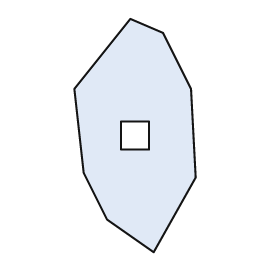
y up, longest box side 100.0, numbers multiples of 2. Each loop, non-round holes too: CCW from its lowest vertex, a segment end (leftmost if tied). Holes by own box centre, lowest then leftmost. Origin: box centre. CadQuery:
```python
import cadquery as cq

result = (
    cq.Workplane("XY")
    .moveTo(8.0, -50.0)
    .lineTo(26.0, -18.0)
    .lineTo(24.0, 20.0)
    .lineTo(12.0, 44.0)
    .lineTo(-2.0, 50.0)
    .lineTo(-26.0, 20.0)
    .lineTo(-22.0, -16.0)
    .lineTo(-12.0, -36.0)
    .close()
    .moveTo(-6.0, -6.0)
    .lineTo(6.0, -6.0)
    .lineTo(6.0, 6.0)
    .lineTo(-6.0, 6.0)
    .close()
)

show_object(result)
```